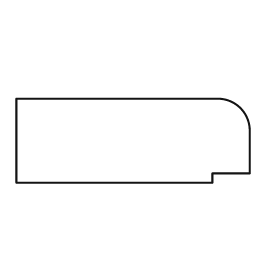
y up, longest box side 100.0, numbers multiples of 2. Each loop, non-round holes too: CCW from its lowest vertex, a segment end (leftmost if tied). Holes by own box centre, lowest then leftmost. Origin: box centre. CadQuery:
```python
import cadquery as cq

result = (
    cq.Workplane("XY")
    .moveTo(-50.0, -18.0)
    .lineTo(34.0, -18.0)
    .lineTo(34.0, -14.0)
    .lineTo(50.0, -14.0)
    .lineTo(50.0, 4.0)
    .threePointArc((46.0, 14.0), (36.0, 18.0))
    .lineTo(-50.0, 18.0)
    .close()
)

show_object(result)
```